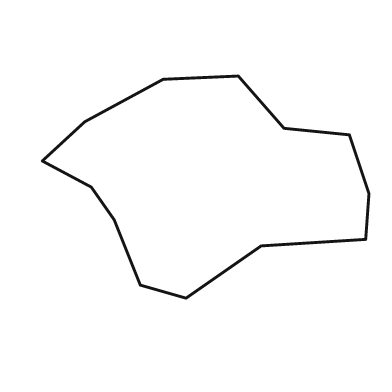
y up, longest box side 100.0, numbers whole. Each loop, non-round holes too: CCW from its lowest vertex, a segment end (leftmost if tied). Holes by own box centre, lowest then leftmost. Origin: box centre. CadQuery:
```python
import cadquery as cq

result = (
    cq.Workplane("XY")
    .moveTo(-6.0, -34.0)
    .lineTo(17.0, -18.0)
    .lineTo(49.0, -16.0)
    .lineTo(50.0, -2.0)
    .lineTo(44.0, 16.0)
    .lineTo(24.0, 18.0)
    .lineTo(10.0, 34.0)
    .lineTo(-13.0, 33.0)
    .lineTo(-37.0, 20.0)
    .lineTo(-50.0, 8.0)
    .lineTo(-35.0, 0.0)
    .lineTo(-28.0, -10.0)
    .lineTo(-20.0, -30.0)
    .close()
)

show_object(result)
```